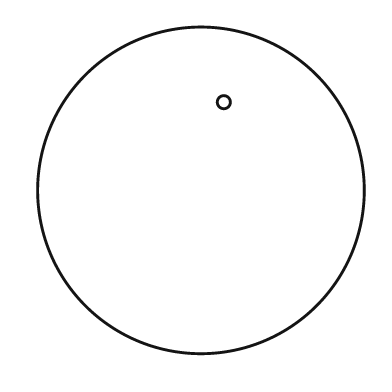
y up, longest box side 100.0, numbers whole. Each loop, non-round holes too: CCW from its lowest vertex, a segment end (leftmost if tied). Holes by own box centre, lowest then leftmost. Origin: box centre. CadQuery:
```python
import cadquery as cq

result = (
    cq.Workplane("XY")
    .moveTo(0.0, 0.0)
    .circle(50.0)
    .moveTo(7.0, 27.0)
    .circle(2.0)
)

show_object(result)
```